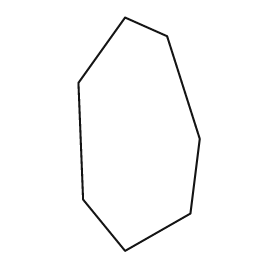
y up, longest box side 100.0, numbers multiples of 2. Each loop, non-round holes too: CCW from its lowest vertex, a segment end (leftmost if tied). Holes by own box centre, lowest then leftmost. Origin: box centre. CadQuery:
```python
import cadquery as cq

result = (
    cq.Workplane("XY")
    .moveTo(-6.0, -50.0)
    .lineTo(22.0, -34.0)
    .lineTo(26.0, -2.0)
    .lineTo(12.0, 42.0)
    .lineTo(-6.0, 50.0)
    .lineTo(-26.0, 22.0)
    .lineTo(-24.0, -28.0)
    .close()
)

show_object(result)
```